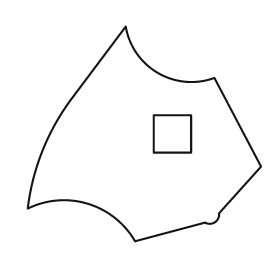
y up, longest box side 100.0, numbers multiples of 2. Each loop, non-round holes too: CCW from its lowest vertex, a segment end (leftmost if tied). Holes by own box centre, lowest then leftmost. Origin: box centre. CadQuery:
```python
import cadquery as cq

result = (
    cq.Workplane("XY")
    .moveTo(-4.0, -46.0)
    .lineTo(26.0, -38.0)
    .threePointArc((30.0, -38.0), (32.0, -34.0))
    .lineTo(50.0, -14.0)
    .lineTo(30.0, 24.0)
    .threePointArc((6.0, 26.0), (-8.0, 46.0))
    .lineTo(-32.0, 14.0)
    .threePointArc((-44.0, -8.0), (-50.0, -32.0))
    .threePointArc((-24.0, -30.0), (-4.0, -46.0))
    .close()
    .moveTo(4.0, -8.0)
    .lineTo(20.0, -8.0)
    .lineTo(20.0, 8.0)
    .lineTo(4.0, 8.0)
    .close()
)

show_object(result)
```